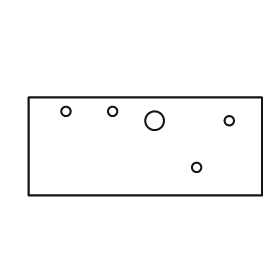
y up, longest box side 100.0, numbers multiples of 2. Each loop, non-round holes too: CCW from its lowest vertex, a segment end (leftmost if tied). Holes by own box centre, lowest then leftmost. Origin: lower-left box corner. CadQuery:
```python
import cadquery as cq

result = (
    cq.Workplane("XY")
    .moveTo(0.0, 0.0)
    .lineTo(100.0, 0.0)
    .lineTo(100.0, 42.0)
    .lineTo(0.0, 42.0)
    .close()
    .moveTo(72.0, 12.0)
    .circle(2.0)
    .moveTo(54.0, 32.0)
    .circle(4.0)
    .moveTo(86.0, 32.0)
    .circle(2.0)
    .moveTo(16.0, 36.0)
    .circle(2.0)
    .moveTo(36.0, 36.0)
    .circle(2.0)
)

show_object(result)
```